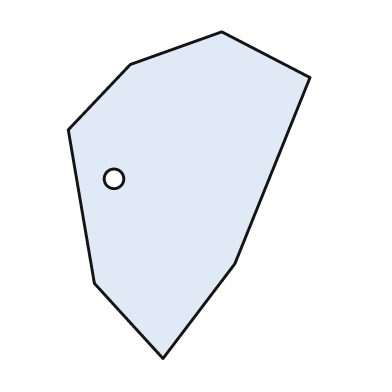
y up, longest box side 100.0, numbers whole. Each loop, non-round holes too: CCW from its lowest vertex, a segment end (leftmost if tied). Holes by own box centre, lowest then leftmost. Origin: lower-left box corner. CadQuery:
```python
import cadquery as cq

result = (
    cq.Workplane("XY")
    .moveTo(29.0, 0.0)
    .lineTo(51.0, 29.0)
    .lineTo(74.0, 86.0)
    .lineTo(47.0, 100.0)
    .lineTo(19.0, 90.0)
    .lineTo(0.0, 70.0)
    .lineTo(8.0, 23.0)
    .close()
    .moveTo(14.0, 55.0)
    .circle(3.0)
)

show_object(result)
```